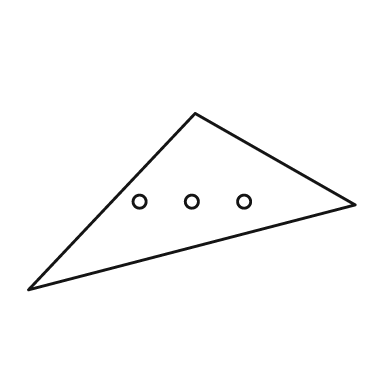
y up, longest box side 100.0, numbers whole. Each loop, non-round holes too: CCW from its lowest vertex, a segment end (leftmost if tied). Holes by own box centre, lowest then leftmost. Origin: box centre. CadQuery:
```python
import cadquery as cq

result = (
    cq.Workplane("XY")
    .moveTo(-50.0, -27.0)
    .lineTo(50.0, -1.0)
    .lineTo(1.0, 27.0)
    .close()
    .moveTo(-16.0, 0.0)
    .circle(2.0)
    .moveTo(0.0, 0.0)
    .circle(2.0)
    .moveTo(16.0, 0.0)
    .circle(2.0)
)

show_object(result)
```